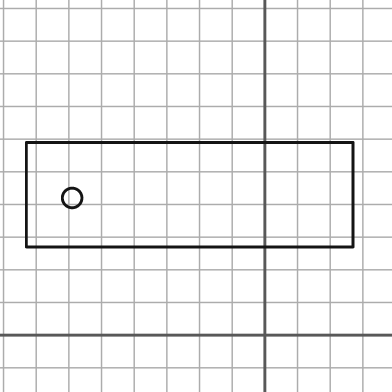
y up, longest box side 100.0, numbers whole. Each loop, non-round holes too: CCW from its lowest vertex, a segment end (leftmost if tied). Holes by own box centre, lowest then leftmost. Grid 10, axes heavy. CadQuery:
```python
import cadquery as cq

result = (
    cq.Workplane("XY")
    .moveTo(-73.0, 27.0)
    .lineTo(27.0, 27.0)
    .lineTo(27.0, 59.0)
    .lineTo(-73.0, 59.0)
    .close()
    .moveTo(-59.0, 42.0)
    .circle(3.0)
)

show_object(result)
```